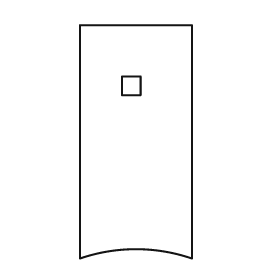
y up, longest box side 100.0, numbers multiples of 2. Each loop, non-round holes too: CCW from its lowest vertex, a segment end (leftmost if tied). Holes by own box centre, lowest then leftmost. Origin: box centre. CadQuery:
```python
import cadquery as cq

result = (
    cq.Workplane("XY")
    .moveTo(-24.0, -50.0)
    .threePointArc((0.0, -46.0), (24.0, -50.0))
    .lineTo(24.0, 50.0)
    .lineTo(-24.0, 50.0)
    .close()
    .moveTo(-6.0, 20.0)
    .lineTo(2.0, 20.0)
    .lineTo(2.0, 28.0)
    .lineTo(-6.0, 28.0)
    .close()
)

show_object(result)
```